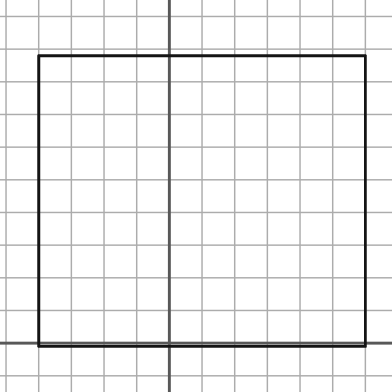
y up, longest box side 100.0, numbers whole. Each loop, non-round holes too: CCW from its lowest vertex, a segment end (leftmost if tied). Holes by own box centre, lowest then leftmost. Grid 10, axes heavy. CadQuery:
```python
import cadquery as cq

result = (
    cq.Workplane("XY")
    .moveTo(-40.0, -1.0)
    .lineTo(60.0, -1.0)
    .lineTo(60.0, 88.0)
    .lineTo(-40.0, 88.0)
    .close()
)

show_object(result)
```